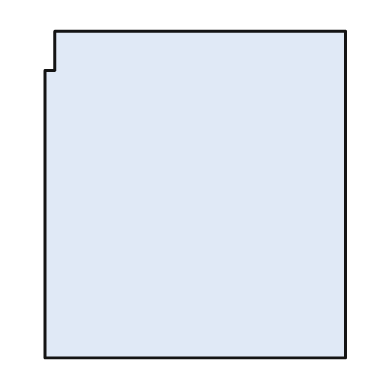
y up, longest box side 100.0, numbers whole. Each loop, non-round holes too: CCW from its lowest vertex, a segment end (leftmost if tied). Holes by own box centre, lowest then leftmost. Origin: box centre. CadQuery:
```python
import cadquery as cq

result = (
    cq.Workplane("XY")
    .moveTo(-46.0, -50.0)
    .lineTo(46.0, -50.0)
    .lineTo(46.0, 50.0)
    .lineTo(-43.0, 50.0)
    .lineTo(-43.0, 38.0)
    .lineTo(-46.0, 38.0)
    .close()
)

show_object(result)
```